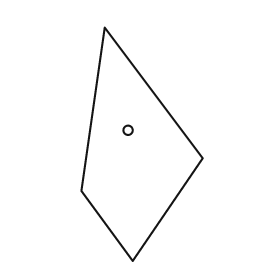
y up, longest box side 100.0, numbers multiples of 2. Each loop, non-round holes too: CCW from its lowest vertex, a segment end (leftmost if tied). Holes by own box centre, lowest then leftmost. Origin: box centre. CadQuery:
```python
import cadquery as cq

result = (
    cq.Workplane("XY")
    .moveTo(-4.0, -50.0)
    .lineTo(26.0, -6.0)
    .lineTo(-16.0, 50.0)
    .lineTo(-26.0, -20.0)
    .close()
    .moveTo(-6.0, 6.0)
    .circle(2.0)
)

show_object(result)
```